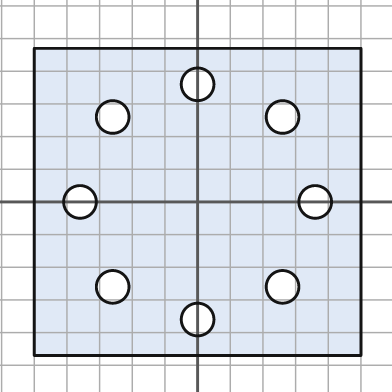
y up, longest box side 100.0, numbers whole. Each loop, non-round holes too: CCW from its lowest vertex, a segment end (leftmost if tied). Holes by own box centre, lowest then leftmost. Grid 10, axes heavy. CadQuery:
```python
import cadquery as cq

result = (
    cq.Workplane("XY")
    .moveTo(-50.0, -47.0)
    .lineTo(50.0, -47.0)
    .lineTo(50.0, 47.0)
    .lineTo(-50.0, 47.0)
    .close()
    .moveTo(0.0, -36.0)
    .circle(5.0)
    .moveTo(-26.0, -26.0)
    .circle(5.0)
    .moveTo(26.0, -26.0)
    .circle(5.0)
    .moveTo(-36.0, 0.0)
    .circle(5.0)
    .moveTo(36.0, 0.0)
    .circle(5.0)
    .moveTo(-26.0, 26.0)
    .circle(5.0)
    .moveTo(26.0, 26.0)
    .circle(5.0)
    .moveTo(0.0, 36.0)
    .circle(5.0)
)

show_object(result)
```